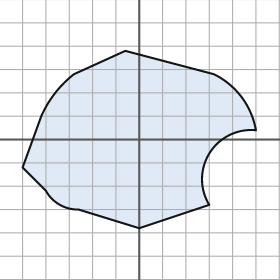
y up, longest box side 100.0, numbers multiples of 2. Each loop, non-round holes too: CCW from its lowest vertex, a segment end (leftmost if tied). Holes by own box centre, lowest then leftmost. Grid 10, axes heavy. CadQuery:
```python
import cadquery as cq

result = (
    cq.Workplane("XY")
    .moveTo(0.0, -38.0)
    .lineTo(30.0, -28.0)
    .threePointArc((30.0, -6.0), (50.0, 4.0))
    .threePointArc((44.0, 18.0), (32.0, 28.0))
    .lineTo(-6.0, 38.0)
    .lineTo(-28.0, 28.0)
    .threePointArc((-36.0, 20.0), (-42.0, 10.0))
    .lineTo(-50.0, -12.0)
    .lineTo(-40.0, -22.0)
    .threePointArc((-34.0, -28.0), (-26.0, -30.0))
    .close()
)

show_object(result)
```